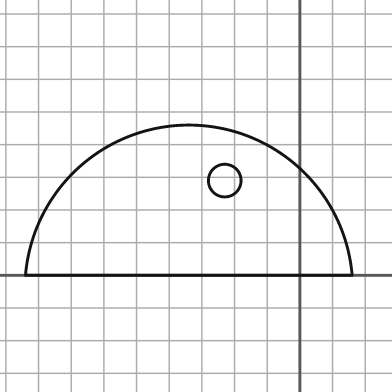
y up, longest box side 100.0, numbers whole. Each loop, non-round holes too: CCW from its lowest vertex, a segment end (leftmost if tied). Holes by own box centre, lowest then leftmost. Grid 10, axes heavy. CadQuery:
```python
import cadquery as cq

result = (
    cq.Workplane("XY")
    .moveTo(-84.0, 0.0)
    .lineTo(16.0, 0.0)
    .threePointArc((-34.0, 46.0), (-84.0, 0.0))
    .close()
    .moveTo(-23.0, 29.0)
    .circle(5.0)
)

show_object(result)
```